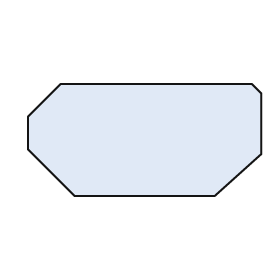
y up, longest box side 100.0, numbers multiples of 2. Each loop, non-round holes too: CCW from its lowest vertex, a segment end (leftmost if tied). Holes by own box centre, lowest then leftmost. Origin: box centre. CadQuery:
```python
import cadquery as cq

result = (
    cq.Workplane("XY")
    .moveTo(-30.0, -24.0)
    .lineTo(30.0, -24.0)
    .lineTo(50.0, -6.0)
    .lineTo(50.0, 20.0)
    .lineTo(46.0, 24.0)
    .lineTo(-36.0, 24.0)
    .lineTo(-50.0, 10.0)
    .lineTo(-50.0, -4.0)
    .close()
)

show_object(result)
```